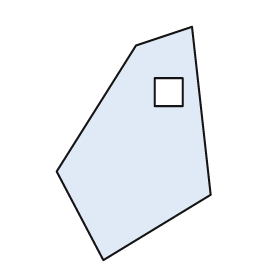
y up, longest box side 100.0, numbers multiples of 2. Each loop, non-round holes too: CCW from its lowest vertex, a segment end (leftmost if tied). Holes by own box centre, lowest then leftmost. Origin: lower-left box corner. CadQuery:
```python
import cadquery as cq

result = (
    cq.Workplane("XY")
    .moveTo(20.0, 0.0)
    .lineTo(66.0, 28.0)
    .lineTo(58.0, 100.0)
    .lineTo(34.0, 92.0)
    .lineTo(0.0, 38.0)
    .close()
    .moveTo(42.0, 66.0)
    .lineTo(54.0, 66.0)
    .lineTo(54.0, 78.0)
    .lineTo(42.0, 78.0)
    .close()
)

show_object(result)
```